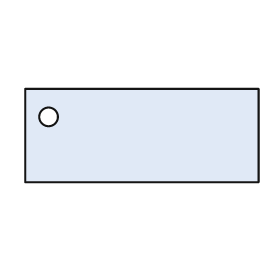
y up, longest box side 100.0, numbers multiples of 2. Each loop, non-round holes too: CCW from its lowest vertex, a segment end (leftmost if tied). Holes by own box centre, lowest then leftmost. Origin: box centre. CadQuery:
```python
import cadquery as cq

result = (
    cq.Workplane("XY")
    .moveTo(-50.0, -20.0)
    .lineTo(50.0, -20.0)
    .lineTo(50.0, 20.0)
    .lineTo(-50.0, 20.0)
    .close()
    .moveTo(-40.0, 8.0)
    .circle(4.0)
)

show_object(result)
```